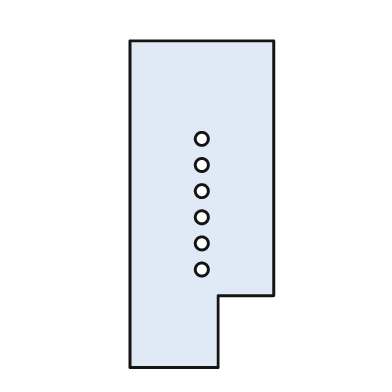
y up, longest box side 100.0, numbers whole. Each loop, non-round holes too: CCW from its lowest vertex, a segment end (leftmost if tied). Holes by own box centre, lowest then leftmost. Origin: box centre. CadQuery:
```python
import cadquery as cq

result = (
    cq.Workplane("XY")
    .moveTo(-22.0, -50.0)
    .lineTo(5.0, -50.0)
    .lineTo(5.0, -28.0)
    .lineTo(22.0, -28.0)
    .lineTo(22.0, 50.0)
    .lineTo(-22.0, 50.0)
    .close()
    .moveTo(0.0, -20.0)
    .circle(2.0)
    .moveTo(0.0, -12.0)
    .circle(2.0)
    .moveTo(0.0, -4.0)
    .circle(2.0)
    .moveTo(0.0, 4.0)
    .circle(2.0)
    .moveTo(0.0, 12.0)
    .circle(2.0)
    .moveTo(0.0, 20.0)
    .circle(2.0)
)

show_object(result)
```